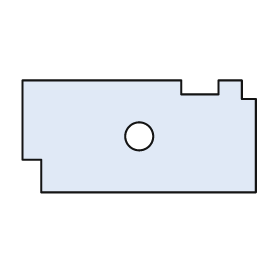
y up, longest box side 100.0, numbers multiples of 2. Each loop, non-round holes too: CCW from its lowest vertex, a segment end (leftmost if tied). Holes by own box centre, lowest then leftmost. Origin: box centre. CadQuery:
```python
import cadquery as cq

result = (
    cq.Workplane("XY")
    .moveTo(-42.0, -24.0)
    .lineTo(50.0, -24.0)
    .lineTo(50.0, 16.0)
    .lineTo(44.0, 16.0)
    .lineTo(44.0, 24.0)
    .lineTo(34.0, 24.0)
    .lineTo(34.0, 18.0)
    .lineTo(18.0, 18.0)
    .lineTo(18.0, 24.0)
    .lineTo(-50.0, 24.0)
    .lineTo(-50.0, -10.0)
    .lineTo(-42.0, -10.0)
    .close()
    .moveTo(0.0, 0.0)
    .circle(6.0)
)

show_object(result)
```